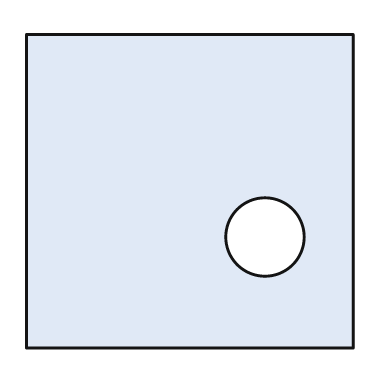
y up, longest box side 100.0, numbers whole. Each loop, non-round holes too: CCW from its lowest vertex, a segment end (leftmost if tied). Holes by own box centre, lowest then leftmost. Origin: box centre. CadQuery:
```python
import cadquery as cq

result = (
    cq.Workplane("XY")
    .moveTo(-50.0, -48.0)
    .lineTo(50.0, -48.0)
    .lineTo(50.0, 48.0)
    .lineTo(-50.0, 48.0)
    .close()
    .moveTo(23.0, -14.0)
    .circle(12.0)
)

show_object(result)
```